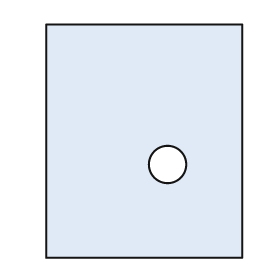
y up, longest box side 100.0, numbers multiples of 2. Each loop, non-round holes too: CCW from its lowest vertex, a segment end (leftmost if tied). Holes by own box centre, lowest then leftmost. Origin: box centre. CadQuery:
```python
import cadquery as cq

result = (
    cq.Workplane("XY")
    .moveTo(-42.0, -50.0)
    .lineTo(42.0, -50.0)
    .lineTo(42.0, 50.0)
    .lineTo(-42.0, 50.0)
    .close()
    .moveTo(10.0, -10.0)
    .circle(8.0)
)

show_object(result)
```